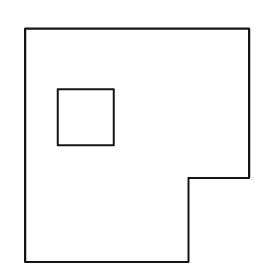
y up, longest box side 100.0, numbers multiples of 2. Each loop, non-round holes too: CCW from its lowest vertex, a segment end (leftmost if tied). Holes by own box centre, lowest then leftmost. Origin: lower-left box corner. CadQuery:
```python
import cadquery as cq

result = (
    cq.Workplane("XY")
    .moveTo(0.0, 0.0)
    .lineTo(70.0, 0.0)
    .lineTo(70.0, 36.0)
    .lineTo(96.0, 36.0)
    .lineTo(96.0, 100.0)
    .lineTo(0.0, 100.0)
    .close()
    .moveTo(14.0, 50.0)
    .lineTo(38.0, 50.0)
    .lineTo(38.0, 74.0)
    .lineTo(14.0, 74.0)
    .close()
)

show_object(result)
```